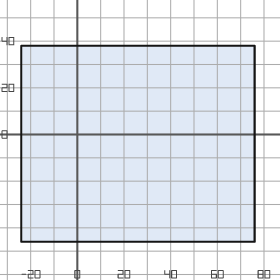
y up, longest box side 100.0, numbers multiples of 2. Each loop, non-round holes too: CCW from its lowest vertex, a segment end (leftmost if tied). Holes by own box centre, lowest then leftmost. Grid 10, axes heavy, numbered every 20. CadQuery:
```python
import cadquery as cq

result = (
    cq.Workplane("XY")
    .moveTo(-24.0, -46.0)
    .lineTo(76.0, -46.0)
    .lineTo(76.0, 38.0)
    .lineTo(-24.0, 38.0)
    .close()
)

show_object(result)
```